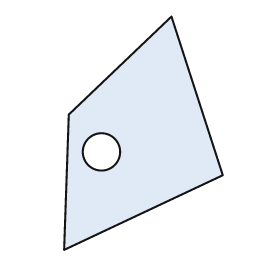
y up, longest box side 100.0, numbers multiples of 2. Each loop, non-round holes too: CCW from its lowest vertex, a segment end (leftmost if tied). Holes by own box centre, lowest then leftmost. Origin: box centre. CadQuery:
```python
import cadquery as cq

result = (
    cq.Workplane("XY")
    .moveTo(-34.0, -50.0)
    .lineTo(34.0, -18.0)
    .lineTo(12.0, 50.0)
    .lineTo(-32.0, 8.0)
    .close()
    .moveTo(-18.0, -8.0)
    .circle(8.0)
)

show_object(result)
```